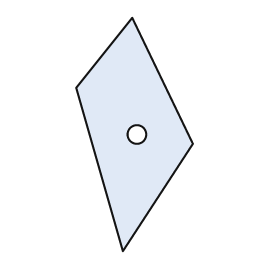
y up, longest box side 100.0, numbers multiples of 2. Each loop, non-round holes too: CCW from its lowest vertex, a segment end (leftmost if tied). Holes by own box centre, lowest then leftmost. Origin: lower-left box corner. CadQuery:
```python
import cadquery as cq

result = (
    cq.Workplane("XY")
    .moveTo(20.0, 0.0)
    .lineTo(50.0, 46.0)
    .lineTo(24.0, 100.0)
    .lineTo(0.0, 70.0)
    .close()
    .moveTo(26.0, 50.0)
    .circle(4.0)
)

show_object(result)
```